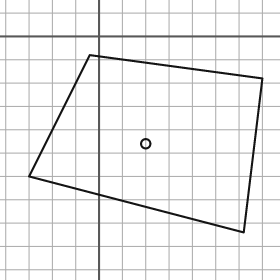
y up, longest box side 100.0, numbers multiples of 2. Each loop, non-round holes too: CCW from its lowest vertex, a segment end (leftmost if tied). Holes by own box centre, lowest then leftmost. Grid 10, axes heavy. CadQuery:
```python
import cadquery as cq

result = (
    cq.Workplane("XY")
    .moveTo(62.0, -84.0)
    .lineTo(70.0, -18.0)
    .lineTo(-4.0, -8.0)
    .lineTo(-30.0, -60.0)
    .close()
    .moveTo(20.0, -46.0)
    .circle(2.0)
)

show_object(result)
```